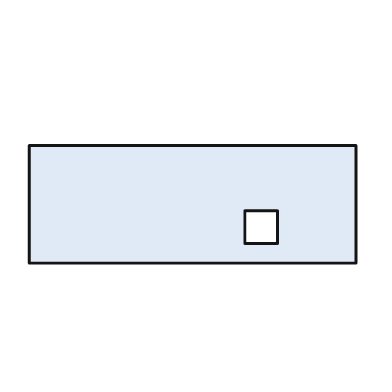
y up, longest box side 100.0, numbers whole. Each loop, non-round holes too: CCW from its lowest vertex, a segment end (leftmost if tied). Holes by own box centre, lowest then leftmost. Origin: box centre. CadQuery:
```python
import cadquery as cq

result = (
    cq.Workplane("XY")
    .moveTo(-50.0, -18.0)
    .lineTo(50.0, -18.0)
    .lineTo(50.0, 18.0)
    .lineTo(-50.0, 18.0)
    .close()
    .moveTo(16.0, -12.0)
    .lineTo(26.0, -12.0)
    .lineTo(26.0, -2.0)
    .lineTo(16.0, -2.0)
    .close()
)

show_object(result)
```